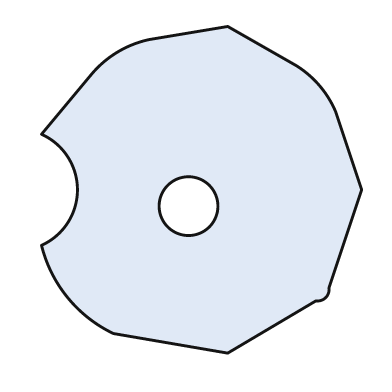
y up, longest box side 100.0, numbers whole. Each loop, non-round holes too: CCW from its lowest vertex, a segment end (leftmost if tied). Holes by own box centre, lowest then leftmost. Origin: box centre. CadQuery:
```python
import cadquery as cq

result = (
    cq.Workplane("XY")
    .moveTo(8.0, -50.0)
    .lineTo(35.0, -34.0)
    .threePointArc((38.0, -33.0), (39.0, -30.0))
    .lineTo(49.0, 0.0)
    .lineTo(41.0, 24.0)
    .threePointArc((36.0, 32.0), (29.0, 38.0))
    .lineTo(8.0, 50.0)
    .lineTo(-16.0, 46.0)
    .threePointArc((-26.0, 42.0), (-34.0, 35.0))
    .lineTo(-49.0, 17.0)
    .threePointArc((-38.0, 0.0), (-49.0, -17.0))
    .threePointArc((-41.0, -33.0), (-27.0, -44.0))
    .close()
    .moveTo(-4.0, -5.0)
    .circle(9.0)
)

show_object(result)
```